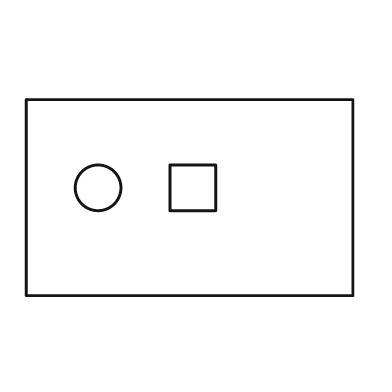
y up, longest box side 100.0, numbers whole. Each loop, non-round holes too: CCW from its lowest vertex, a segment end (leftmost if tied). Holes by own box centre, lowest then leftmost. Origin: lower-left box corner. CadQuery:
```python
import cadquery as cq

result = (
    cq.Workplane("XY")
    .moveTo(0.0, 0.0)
    .lineTo(100.0, 0.0)
    .lineTo(100.0, 60.0)
    .lineTo(0.0, 60.0)
    .close()
    .moveTo(22.0, 33.0)
    .circle(7.0)
    .moveTo(44.0, 26.0)
    .lineTo(58.0, 26.0)
    .lineTo(58.0, 40.0)
    .lineTo(44.0, 40.0)
    .close()
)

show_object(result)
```